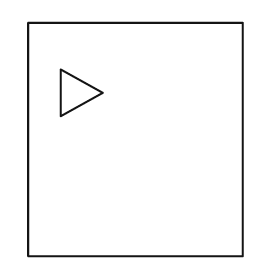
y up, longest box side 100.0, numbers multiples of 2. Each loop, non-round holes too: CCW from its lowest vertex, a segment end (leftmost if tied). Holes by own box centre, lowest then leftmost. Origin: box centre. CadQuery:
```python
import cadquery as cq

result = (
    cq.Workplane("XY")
    .moveTo(-46.0, -50.0)
    .lineTo(46.0, -50.0)
    .lineTo(46.0, 50.0)
    .lineTo(-46.0, 50.0)
    .close()
    .moveTo(-32.0, 10.0)
    .lineTo(-14.0, 20.0)
    .lineTo(-32.0, 30.0)
    .close()
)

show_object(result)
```